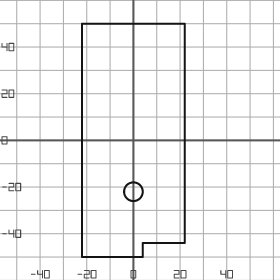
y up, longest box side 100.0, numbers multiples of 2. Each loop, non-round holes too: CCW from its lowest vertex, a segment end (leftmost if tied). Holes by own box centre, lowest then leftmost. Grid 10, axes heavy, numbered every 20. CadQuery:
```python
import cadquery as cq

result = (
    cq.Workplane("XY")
    .moveTo(-22.0, -50.0)
    .lineTo(4.0, -50.0)
    .lineTo(4.0, -44.0)
    .lineTo(22.0, -44.0)
    .lineTo(22.0, 50.0)
    .lineTo(-22.0, 50.0)
    .close()
    .moveTo(0.0, -22.0)
    .circle(4.0)
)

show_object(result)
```